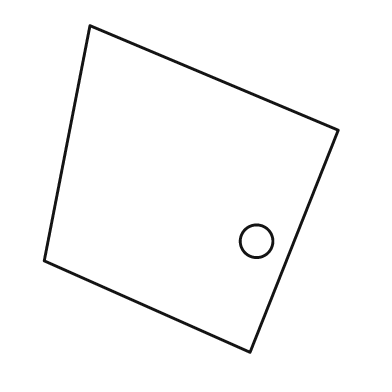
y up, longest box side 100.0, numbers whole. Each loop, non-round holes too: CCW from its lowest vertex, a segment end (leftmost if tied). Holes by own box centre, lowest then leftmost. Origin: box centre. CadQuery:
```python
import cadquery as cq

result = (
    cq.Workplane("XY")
    .moveTo(18.0, -50.0)
    .lineTo(45.0, 18.0)
    .lineTo(-31.0, 50.0)
    .lineTo(-45.0, -22.0)
    .close()
    .moveTo(20.0, -16.0)
    .circle(5.0)
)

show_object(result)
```